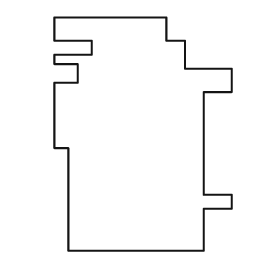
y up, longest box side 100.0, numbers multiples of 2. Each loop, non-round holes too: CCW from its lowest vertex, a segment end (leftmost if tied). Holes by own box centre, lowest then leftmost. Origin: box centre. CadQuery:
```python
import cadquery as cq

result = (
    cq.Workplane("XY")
    .moveTo(-32.0, -50.0)
    .lineTo(26.0, -50.0)
    .lineTo(26.0, -32.0)
    .lineTo(38.0, -32.0)
    .lineTo(38.0, -26.0)
    .lineTo(26.0, -26.0)
    .lineTo(26.0, 18.0)
    .lineTo(38.0, 18.0)
    .lineTo(38.0, 28.0)
    .lineTo(18.0, 28.0)
    .lineTo(18.0, 40.0)
    .lineTo(10.0, 40.0)
    .lineTo(10.0, 50.0)
    .lineTo(-38.0, 50.0)
    .lineTo(-38.0, 40.0)
    .lineTo(-22.0, 40.0)
    .lineTo(-22.0, 34.0)
    .lineTo(-38.0, 34.0)
    .lineTo(-38.0, 30.0)
    .lineTo(-28.0, 30.0)
    .lineTo(-28.0, 22.0)
    .lineTo(-38.0, 22.0)
    .lineTo(-38.0, -6.0)
    .lineTo(-32.0, -6.0)
    .close()
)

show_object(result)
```